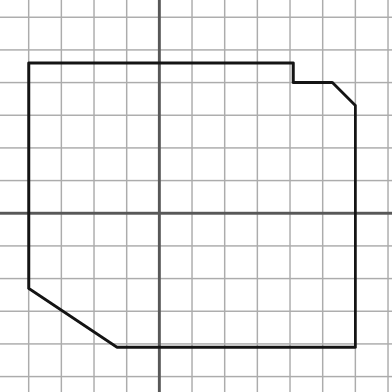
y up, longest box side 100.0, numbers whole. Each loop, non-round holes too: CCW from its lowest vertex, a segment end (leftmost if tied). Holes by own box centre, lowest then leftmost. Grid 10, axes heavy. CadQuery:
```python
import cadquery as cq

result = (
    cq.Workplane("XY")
    .moveTo(-13.0, -41.0)
    .lineTo(60.0, -41.0)
    .lineTo(60.0, 33.0)
    .lineTo(53.0, 40.0)
    .lineTo(41.0, 40.0)
    .lineTo(41.0, 46.0)
    .lineTo(-40.0, 46.0)
    .lineTo(-40.0, -23.0)
    .close()
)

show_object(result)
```